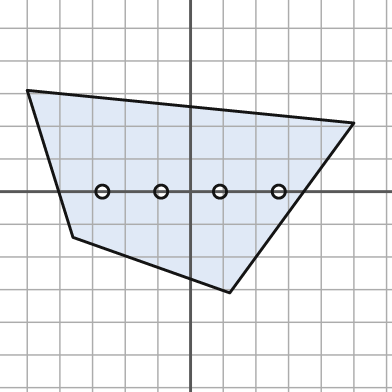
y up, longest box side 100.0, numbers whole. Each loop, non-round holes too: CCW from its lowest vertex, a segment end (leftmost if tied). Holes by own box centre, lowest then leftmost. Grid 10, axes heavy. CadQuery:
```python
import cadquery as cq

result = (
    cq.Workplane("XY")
    .moveTo(12.0, -31.0)
    .lineTo(50.0, 21.0)
    .lineTo(-50.0, 31.0)
    .lineTo(-36.0, -14.0)
    .close()
    .moveTo(-27.0, 0.0)
    .circle(2.0)
    .moveTo(-9.0, 0.0)
    .circle(2.0)
    .moveTo(9.0, 0.0)
    .circle(2.0)
    .moveTo(27.0, 0.0)
    .circle(2.0)
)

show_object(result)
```